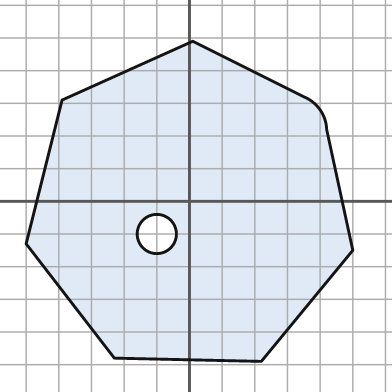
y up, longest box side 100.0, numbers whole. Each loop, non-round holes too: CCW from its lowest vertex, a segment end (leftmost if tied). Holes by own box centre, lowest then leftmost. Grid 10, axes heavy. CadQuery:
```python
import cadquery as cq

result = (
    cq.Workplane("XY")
    .moveTo(22.0, -49.0)
    .lineTo(50.0, -15.0)
    .lineTo(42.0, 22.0)
    .threePointArc((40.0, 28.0), (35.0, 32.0))
    .lineTo(1.0, 49.0)
    .lineTo(-39.0, 31.0)
    .lineTo(-50.0, -13.0)
    .lineTo(-23.0, -48.0)
    .close()
    .moveTo(-10.0, -10.0)
    .circle(6.0)
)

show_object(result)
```